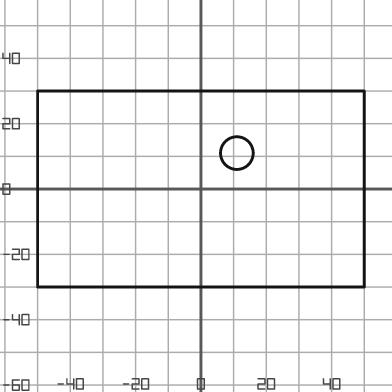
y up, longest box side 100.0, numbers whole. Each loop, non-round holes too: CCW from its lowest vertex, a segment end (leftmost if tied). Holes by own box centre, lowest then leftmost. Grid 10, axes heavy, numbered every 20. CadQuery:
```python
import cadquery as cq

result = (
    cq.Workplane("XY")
    .moveTo(-50.0, -30.0)
    .lineTo(50.0, -30.0)
    .lineTo(50.0, 30.0)
    .lineTo(-50.0, 30.0)
    .close()
    .moveTo(11.0, 11.0)
    .circle(5.0)
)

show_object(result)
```